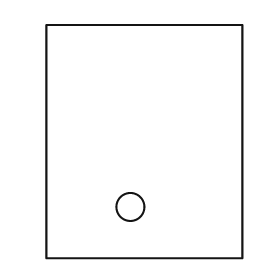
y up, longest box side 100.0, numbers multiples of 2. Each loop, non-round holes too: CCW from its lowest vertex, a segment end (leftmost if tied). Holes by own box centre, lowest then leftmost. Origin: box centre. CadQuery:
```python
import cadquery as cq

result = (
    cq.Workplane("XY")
    .moveTo(-42.0, -50.0)
    .lineTo(42.0, -50.0)
    .lineTo(42.0, 50.0)
    .lineTo(-42.0, 50.0)
    .close()
    .moveTo(-6.0, -28.0)
    .circle(6.0)
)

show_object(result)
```